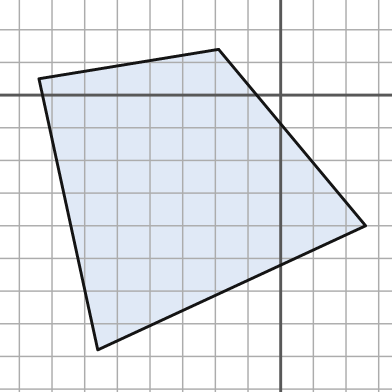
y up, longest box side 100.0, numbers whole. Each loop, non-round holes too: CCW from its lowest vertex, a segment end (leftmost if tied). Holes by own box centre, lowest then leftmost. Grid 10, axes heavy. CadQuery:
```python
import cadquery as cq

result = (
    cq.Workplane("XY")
    .moveTo(-56.0, -78.0)
    .lineTo(26.0, -40.0)
    .lineTo(-19.0, 14.0)
    .lineTo(-74.0, 5.0)
    .close()
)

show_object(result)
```